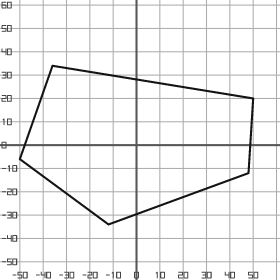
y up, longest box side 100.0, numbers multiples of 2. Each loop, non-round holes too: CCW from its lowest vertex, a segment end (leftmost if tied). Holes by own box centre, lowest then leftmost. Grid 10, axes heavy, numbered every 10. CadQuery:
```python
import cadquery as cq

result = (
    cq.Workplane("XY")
    .moveTo(-12.0, -34.0)
    .lineTo(48.0, -12.0)
    .lineTo(50.0, 20.0)
    .lineTo(-36.0, 34.0)
    .lineTo(-50.0, -6.0)
    .close()
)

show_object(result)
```